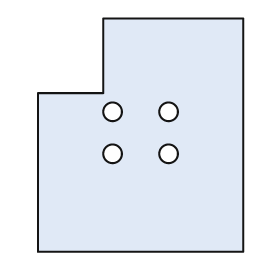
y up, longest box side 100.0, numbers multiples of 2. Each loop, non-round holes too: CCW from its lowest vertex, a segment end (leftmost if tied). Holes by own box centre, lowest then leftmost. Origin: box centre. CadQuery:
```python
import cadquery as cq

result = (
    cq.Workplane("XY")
    .moveTo(-44.0, -50.0)
    .lineTo(44.0, -50.0)
    .lineTo(44.0, 50.0)
    .lineTo(-16.0, 50.0)
    .lineTo(-16.0, 18.0)
    .lineTo(-44.0, 18.0)
    .close()
    .moveTo(-12.0, -8.0)
    .circle(4.0)
    .moveTo(12.0, -8.0)
    .circle(4.0)
    .moveTo(-12.0, 10.0)
    .circle(4.0)
    .moveTo(12.0, 10.0)
    .circle(4.0)
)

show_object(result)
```